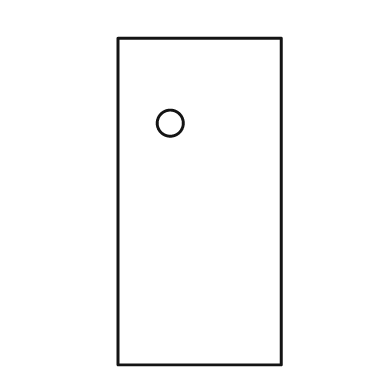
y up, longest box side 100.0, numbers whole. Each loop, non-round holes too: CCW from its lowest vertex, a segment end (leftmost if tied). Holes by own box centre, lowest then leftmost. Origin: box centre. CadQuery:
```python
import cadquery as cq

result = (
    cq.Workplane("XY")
    .moveTo(-25.0, -50.0)
    .lineTo(25.0, -50.0)
    .lineTo(25.0, 50.0)
    .lineTo(-25.0, 50.0)
    .close()
    .moveTo(-9.0, 24.0)
    .circle(4.0)
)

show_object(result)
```